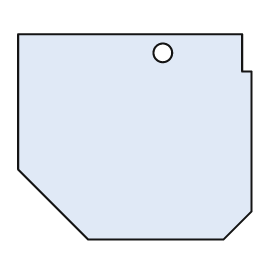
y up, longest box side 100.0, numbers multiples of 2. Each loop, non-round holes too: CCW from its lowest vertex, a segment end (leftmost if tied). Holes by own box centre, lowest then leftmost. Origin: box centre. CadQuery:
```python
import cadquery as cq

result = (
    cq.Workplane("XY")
    .moveTo(-20.0, -44.0)
    .lineTo(38.0, -44.0)
    .lineTo(50.0, -32.0)
    .lineTo(50.0, 28.0)
    .lineTo(46.0, 28.0)
    .lineTo(46.0, 44.0)
    .lineTo(-50.0, 44.0)
    .lineTo(-50.0, -14.0)
    .close()
    .moveTo(12.0, 36.0)
    .circle(4.0)
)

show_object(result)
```